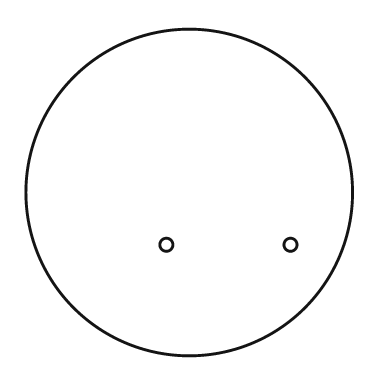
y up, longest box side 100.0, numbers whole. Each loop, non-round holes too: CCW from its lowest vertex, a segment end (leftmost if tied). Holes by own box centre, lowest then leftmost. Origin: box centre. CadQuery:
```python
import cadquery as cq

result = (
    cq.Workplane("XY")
    .moveTo(0.0, 0.0)
    .circle(50.0)
    .moveTo(-7.0, -16.0)
    .circle(2.0)
    .moveTo(31.0, -16.0)
    .circle(2.0)
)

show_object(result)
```